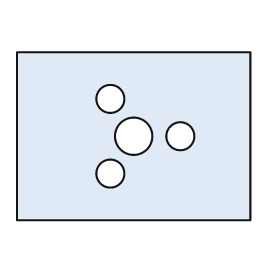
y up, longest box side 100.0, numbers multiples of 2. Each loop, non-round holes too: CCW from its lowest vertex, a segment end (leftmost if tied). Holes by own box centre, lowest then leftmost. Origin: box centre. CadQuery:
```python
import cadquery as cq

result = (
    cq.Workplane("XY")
    .moveTo(-50.0, -36.0)
    .lineTo(50.0, -36.0)
    .lineTo(50.0, 36.0)
    .lineTo(-50.0, 36.0)
    .close()
    .moveTo(-10.0, -16.0)
    .circle(6.0)
    .moveTo(0.0, 0.0)
    .circle(8.0)
    .moveTo(20.0, 0.0)
    .circle(6.0)
    .moveTo(-10.0, 16.0)
    .circle(6.0)
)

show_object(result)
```